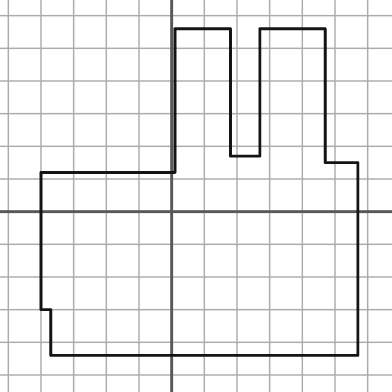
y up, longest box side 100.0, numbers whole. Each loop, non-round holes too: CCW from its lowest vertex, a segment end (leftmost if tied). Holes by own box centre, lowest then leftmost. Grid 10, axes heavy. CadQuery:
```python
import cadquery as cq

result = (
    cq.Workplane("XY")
    .moveTo(-37.0, -44.0)
    .lineTo(57.0, -44.0)
    .lineTo(57.0, 15.0)
    .lineTo(47.0, 15.0)
    .lineTo(47.0, 56.0)
    .lineTo(27.0, 56.0)
    .lineTo(27.0, 17.0)
    .lineTo(18.0, 17.0)
    .lineTo(18.0, 56.0)
    .lineTo(1.0, 56.0)
    .lineTo(1.0, 12.0)
    .lineTo(-40.0, 12.0)
    .lineTo(-40.0, -30.0)
    .lineTo(-37.0, -30.0)
    .close()
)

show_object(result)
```